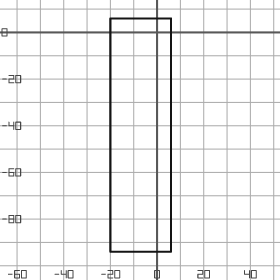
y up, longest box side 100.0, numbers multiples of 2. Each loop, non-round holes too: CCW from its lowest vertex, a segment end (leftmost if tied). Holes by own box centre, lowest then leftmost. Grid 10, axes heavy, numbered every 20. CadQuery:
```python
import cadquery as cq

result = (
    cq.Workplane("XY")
    .moveTo(-20.0, -94.0)
    .lineTo(6.0, -94.0)
    .lineTo(6.0, 6.0)
    .lineTo(-20.0, 6.0)
    .close()
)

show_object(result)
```